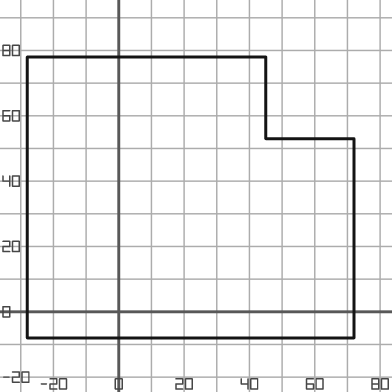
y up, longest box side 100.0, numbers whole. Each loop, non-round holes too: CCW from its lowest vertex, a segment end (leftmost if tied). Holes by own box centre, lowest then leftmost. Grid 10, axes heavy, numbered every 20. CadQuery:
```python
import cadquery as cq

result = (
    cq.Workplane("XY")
    .moveTo(-28.0, -8.0)
    .lineTo(72.0, -8.0)
    .lineTo(72.0, 53.0)
    .lineTo(45.0, 53.0)
    .lineTo(45.0, 78.0)
    .lineTo(-28.0, 78.0)
    .close()
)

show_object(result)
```